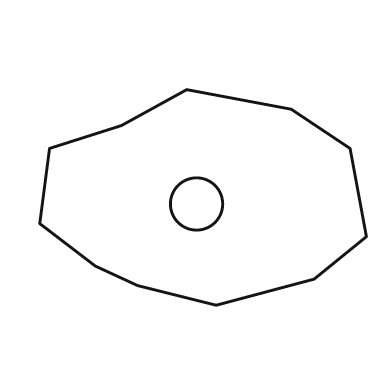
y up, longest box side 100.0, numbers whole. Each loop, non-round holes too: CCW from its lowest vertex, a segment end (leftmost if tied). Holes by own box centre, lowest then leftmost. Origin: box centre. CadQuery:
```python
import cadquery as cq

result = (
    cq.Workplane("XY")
    .moveTo(4.0, -33.0)
    .lineTo(34.0, -25.0)
    .lineTo(50.0, -12.0)
    .lineTo(45.0, 15.0)
    .lineTo(27.0, 27.0)
    .lineTo(-5.0, 33.0)
    .lineTo(-25.0, 22.0)
    .lineTo(-47.0, 15.0)
    .lineTo(-50.0, -8.0)
    .lineTo(-33.0, -21.0)
    .lineTo(-20.0, -27.0)
    .close()
    .moveTo(-2.0, -2.0)
    .circle(8.0)
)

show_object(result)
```